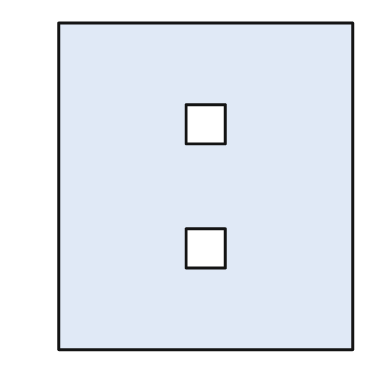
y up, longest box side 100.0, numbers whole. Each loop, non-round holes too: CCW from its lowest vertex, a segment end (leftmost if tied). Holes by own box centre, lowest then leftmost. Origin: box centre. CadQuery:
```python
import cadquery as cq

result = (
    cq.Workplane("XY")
    .moveTo(-45.0, -50.0)
    .lineTo(45.0, -50.0)
    .lineTo(45.0, 50.0)
    .lineTo(-45.0, 50.0)
    .close()
    .moveTo(-6.0, -25.0)
    .lineTo(6.0, -25.0)
    .lineTo(6.0, -13.0)
    .lineTo(-6.0, -13.0)
    .close()
    .moveTo(-6.0, 13.0)
    .lineTo(6.0, 13.0)
    .lineTo(6.0, 25.0)
    .lineTo(-6.0, 25.0)
    .close()
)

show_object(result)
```